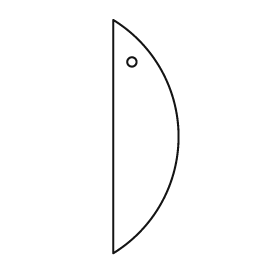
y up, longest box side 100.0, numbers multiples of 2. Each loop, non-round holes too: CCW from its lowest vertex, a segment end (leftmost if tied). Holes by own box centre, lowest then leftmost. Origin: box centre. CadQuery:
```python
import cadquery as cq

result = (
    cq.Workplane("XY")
    .moveTo(-14.0, -50.0)
    .threePointArc((14.0, 0.0), (-14.0, 50.0))
    .close()
    .moveTo(-6.0, 32.0)
    .circle(2.0)
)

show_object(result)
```